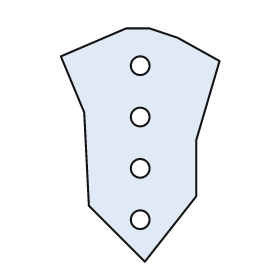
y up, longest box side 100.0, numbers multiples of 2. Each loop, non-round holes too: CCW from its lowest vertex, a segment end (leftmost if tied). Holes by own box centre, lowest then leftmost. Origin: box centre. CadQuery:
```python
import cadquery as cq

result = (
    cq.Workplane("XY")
    .moveTo(2.0, -50.0)
    .lineTo(24.0, -22.0)
    .lineTo(24.0, 2.0)
    .lineTo(34.0, 36.0)
    .lineTo(16.0, 46.0)
    .lineTo(4.0, 50.0)
    .lineTo(-6.0, 50.0)
    .lineTo(-34.0, 38.0)
    .lineTo(-24.0, 14.0)
    .lineTo(-22.0, -26.0)
    .close()
    .moveTo(0.0, -32.0)
    .circle(4.0)
    .moveTo(0.0, -10.0)
    .circle(4.0)
    .moveTo(0.0, 12.0)
    .circle(4.0)
    .moveTo(0.0, 34.0)
    .circle(4.0)
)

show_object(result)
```